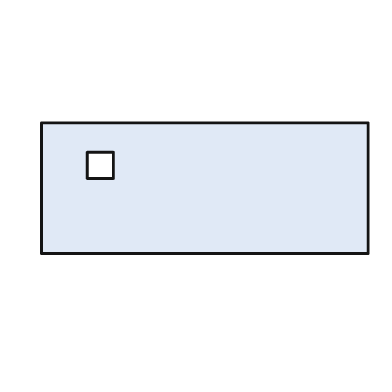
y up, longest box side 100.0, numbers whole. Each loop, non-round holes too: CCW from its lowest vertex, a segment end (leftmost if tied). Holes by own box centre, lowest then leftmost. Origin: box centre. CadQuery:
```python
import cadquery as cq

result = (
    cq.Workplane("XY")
    .moveTo(-50.0, -20.0)
    .lineTo(50.0, -20.0)
    .lineTo(50.0, 20.0)
    .lineTo(-50.0, 20.0)
    .close()
    .moveTo(-36.0, 3.0)
    .lineTo(-28.0, 3.0)
    .lineTo(-28.0, 11.0)
    .lineTo(-36.0, 11.0)
    .close()
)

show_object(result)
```